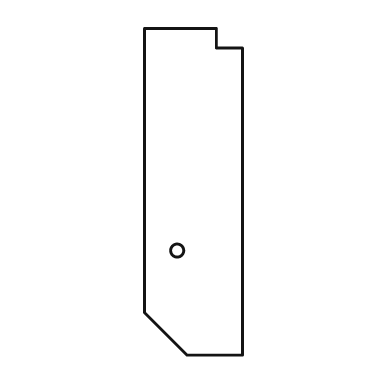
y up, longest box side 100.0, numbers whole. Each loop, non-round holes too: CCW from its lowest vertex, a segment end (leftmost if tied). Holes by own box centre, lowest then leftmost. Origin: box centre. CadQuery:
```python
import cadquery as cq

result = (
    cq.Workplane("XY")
    .moveTo(-2.0, -50.0)
    .lineTo(15.0, -50.0)
    .lineTo(15.0, 44.0)
    .lineTo(7.0, 44.0)
    .lineTo(7.0, 50.0)
    .lineTo(-15.0, 50.0)
    .lineTo(-15.0, -37.0)
    .close()
    .moveTo(-5.0, -18.0)
    .circle(2.0)
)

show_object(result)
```